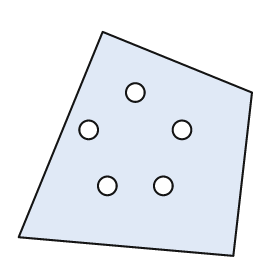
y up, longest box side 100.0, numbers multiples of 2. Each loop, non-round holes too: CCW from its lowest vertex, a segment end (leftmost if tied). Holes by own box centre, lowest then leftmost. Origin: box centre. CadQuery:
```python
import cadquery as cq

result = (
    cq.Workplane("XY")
    .moveTo(42.0, -48.0)
    .lineTo(50.0, 22.0)
    .lineTo(-14.0, 48.0)
    .lineTo(-50.0, -40.0)
    .close()
    .moveTo(-12.0, -18.0)
    .circle(4.0)
    .moveTo(12.0, -18.0)
    .circle(4.0)
    .moveTo(-20.0, 6.0)
    .circle(4.0)
    .moveTo(20.0, 6.0)
    .circle(4.0)
    .moveTo(0.0, 22.0)
    .circle(4.0)
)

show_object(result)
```